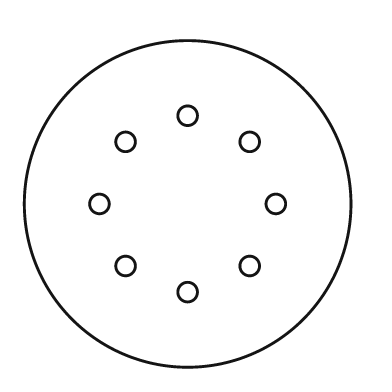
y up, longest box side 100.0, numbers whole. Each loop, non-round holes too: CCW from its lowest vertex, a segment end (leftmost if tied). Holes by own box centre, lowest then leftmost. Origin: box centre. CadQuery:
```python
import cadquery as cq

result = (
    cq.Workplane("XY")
    .moveTo(0.0, 0.0)
    .circle(50.0)
    .moveTo(0.0, -27.0)
    .circle(3.0)
    .moveTo(-19.0, -19.0)
    .circle(3.0)
    .moveTo(19.0, -19.0)
    .circle(3.0)
    .moveTo(-27.0, 0.0)
    .circle(3.0)
    .moveTo(27.0, 0.0)
    .circle(3.0)
    .moveTo(-19.0, 19.0)
    .circle(3.0)
    .moveTo(19.0, 19.0)
    .circle(3.0)
    .moveTo(0.0, 27.0)
    .circle(3.0)
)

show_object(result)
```